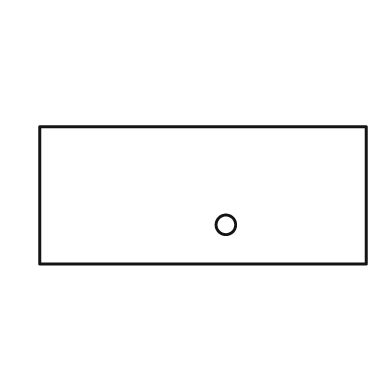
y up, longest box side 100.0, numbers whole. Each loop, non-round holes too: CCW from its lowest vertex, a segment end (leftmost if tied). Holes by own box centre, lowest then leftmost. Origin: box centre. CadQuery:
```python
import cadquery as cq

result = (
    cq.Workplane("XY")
    .moveTo(-50.0, -21.0)
    .lineTo(50.0, -21.0)
    .lineTo(50.0, 21.0)
    .lineTo(-50.0, 21.0)
    .close()
    .moveTo(7.0, -9.0)
    .circle(3.0)
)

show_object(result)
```